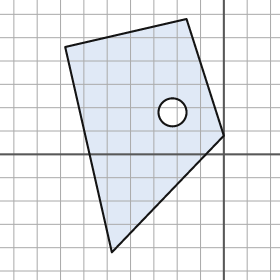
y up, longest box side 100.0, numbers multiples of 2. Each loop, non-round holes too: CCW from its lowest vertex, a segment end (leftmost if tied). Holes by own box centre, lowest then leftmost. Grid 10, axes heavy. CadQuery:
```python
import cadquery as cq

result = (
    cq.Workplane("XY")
    .moveTo(-48.0, -42.0)
    .lineTo(0.0, 8.0)
    .lineTo(-16.0, 58.0)
    .lineTo(-68.0, 46.0)
    .close()
    .moveTo(-22.0, 18.0)
    .circle(6.0)
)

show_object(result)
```